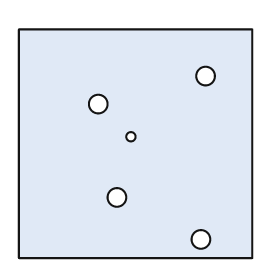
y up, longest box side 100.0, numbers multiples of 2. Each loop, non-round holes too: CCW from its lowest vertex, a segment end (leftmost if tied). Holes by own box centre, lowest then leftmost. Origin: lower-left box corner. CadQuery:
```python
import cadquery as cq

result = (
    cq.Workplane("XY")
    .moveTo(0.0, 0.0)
    .lineTo(100.0, 0.0)
    .lineTo(100.0, 98.0)
    .lineTo(0.0, 98.0)
    .close()
    .moveTo(78.0, 8.0)
    .circle(4.0)
    .moveTo(42.0, 26.0)
    .circle(4.0)
    .moveTo(48.0, 52.0)
    .circle(2.0)
    .moveTo(34.0, 66.0)
    .circle(4.0)
    .moveTo(80.0, 78.0)
    .circle(4.0)
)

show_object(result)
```